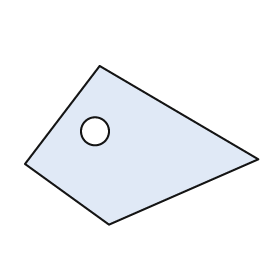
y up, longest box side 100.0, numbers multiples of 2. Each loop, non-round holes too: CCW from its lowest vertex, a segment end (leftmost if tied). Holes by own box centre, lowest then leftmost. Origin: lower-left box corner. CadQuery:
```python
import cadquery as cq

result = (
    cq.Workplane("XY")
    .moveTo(36.0, 0.0)
    .lineTo(100.0, 28.0)
    .lineTo(32.0, 68.0)
    .lineTo(0.0, 26.0)
    .close()
    .moveTo(30.0, 40.0)
    .circle(6.0)
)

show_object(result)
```